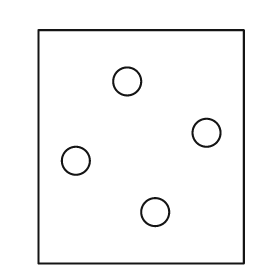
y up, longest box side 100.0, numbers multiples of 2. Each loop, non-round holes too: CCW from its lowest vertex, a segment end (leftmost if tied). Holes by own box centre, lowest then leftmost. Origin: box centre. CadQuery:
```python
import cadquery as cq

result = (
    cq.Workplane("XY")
    .moveTo(-44.0, -50.0)
    .lineTo(44.0, -50.0)
    .lineTo(44.0, 50.0)
    .lineTo(-44.0, 50.0)
    .close()
    .moveTo(6.0, -28.0)
    .circle(6.0)
    .moveTo(-28.0, -6.0)
    .circle(6.0)
    .moveTo(28.0, 6.0)
    .circle(6.0)
    .moveTo(-6.0, 28.0)
    .circle(6.0)
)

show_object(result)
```